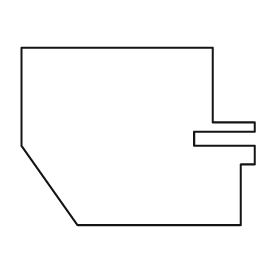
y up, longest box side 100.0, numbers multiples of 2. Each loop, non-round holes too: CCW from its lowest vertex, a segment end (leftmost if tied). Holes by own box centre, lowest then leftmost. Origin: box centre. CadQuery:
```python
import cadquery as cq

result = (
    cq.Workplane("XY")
    .moveTo(-26.0, -38.0)
    .lineTo(44.0, -38.0)
    .lineTo(44.0, -12.0)
    .lineTo(50.0, -12.0)
    .lineTo(50.0, -4.0)
    .lineTo(24.0, -4.0)
    .lineTo(24.0, 2.0)
    .lineTo(50.0, 2.0)
    .lineTo(50.0, 6.0)
    .lineTo(32.0, 6.0)
    .lineTo(32.0, 38.0)
    .lineTo(-50.0, 38.0)
    .lineTo(-50.0, -4.0)
    .close()
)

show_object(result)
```